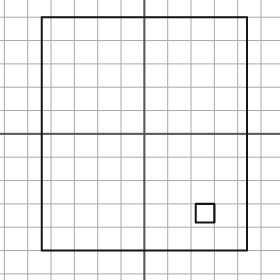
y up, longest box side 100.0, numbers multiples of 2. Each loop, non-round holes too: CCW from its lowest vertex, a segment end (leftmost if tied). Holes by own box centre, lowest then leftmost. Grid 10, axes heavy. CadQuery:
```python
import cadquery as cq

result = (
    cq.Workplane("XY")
    .moveTo(-44.0, -50.0)
    .lineTo(44.0, -50.0)
    .lineTo(44.0, 50.0)
    .lineTo(-44.0, 50.0)
    .close()
    .moveTo(22.0, -38.0)
    .lineTo(30.0, -38.0)
    .lineTo(30.0, -30.0)
    .lineTo(22.0, -30.0)
    .close()
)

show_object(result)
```